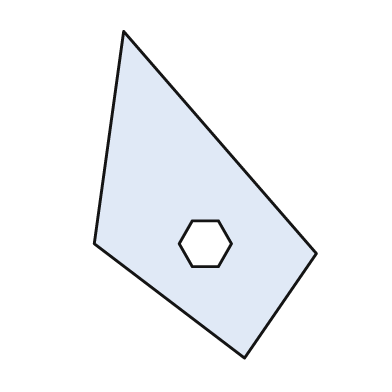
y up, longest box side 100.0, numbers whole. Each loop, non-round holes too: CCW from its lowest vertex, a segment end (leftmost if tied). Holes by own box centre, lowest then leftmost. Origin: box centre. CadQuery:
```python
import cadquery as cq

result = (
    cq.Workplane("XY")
    .moveTo(12.0, -50.0)
    .lineTo(34.0, -18.0)
    .lineTo(-25.0, 50.0)
    .lineTo(-34.0, -15.0)
    .close()
    .moveTo(-4.0, -22.0)
    .lineTo(4.0, -22.0)
    .lineTo(8.0, -15.0)
    .lineTo(4.0, -8.0)
    .lineTo(-4.0, -8.0)
    .lineTo(-8.0, -15.0)
    .close()
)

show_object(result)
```